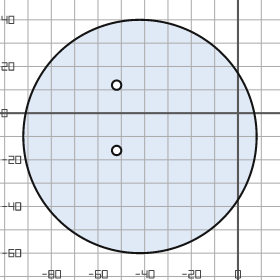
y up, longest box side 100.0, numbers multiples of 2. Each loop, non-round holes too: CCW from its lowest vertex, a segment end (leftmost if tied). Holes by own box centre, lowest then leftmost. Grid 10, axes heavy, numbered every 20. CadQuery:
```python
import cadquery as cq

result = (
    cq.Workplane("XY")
    .moveTo(-42.0, -10.0)
    .circle(50.0)
    .moveTo(-52.0, -16.0)
    .circle(2.0)
    .moveTo(-52.0, 12.0)
    .circle(2.0)
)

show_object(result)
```